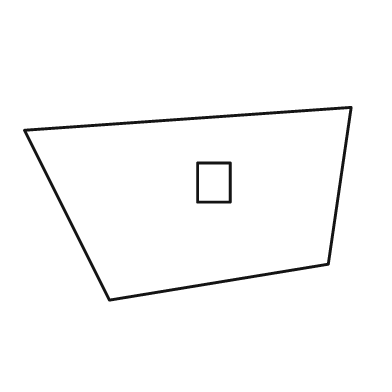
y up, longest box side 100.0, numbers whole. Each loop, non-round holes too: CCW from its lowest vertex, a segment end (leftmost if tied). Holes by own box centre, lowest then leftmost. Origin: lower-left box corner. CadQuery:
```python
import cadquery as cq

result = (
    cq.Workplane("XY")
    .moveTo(26.0, 0.0)
    .lineTo(93.0, 11.0)
    .lineTo(100.0, 59.0)
    .lineTo(0.0, 52.0)
    .close()
    .moveTo(53.0, 30.0)
    .lineTo(63.0, 30.0)
    .lineTo(63.0, 42.0)
    .lineTo(53.0, 42.0)
    .close()
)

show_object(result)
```